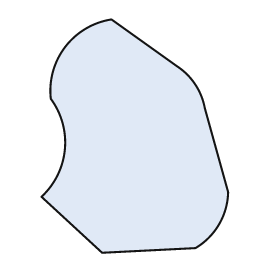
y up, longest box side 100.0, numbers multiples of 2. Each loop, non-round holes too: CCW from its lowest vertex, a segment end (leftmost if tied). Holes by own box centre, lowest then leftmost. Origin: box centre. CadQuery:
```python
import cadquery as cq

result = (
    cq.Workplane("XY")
    .moveTo(-14.0, -50.0)
    .lineTo(26.0, -48.0)
    .threePointArc((36.0, -38.0), (40.0, -24.0))
    .lineTo(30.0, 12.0)
    .threePointArc((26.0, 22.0), (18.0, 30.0))
    .lineTo(-10.0, 50.0)
    .threePointArc((-30.0, 38.0), (-36.0, 16.0))
    .threePointArc((-30.0, -6.0), (-40.0, -26.0))
    .close()
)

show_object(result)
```